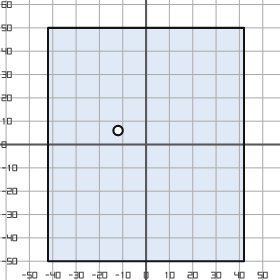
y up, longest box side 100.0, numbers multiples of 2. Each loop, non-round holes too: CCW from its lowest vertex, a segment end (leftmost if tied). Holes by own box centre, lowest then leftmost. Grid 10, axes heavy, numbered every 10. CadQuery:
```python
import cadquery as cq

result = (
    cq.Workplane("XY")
    .moveTo(-42.0, -50.0)
    .lineTo(42.0, -50.0)
    .lineTo(42.0, 50.0)
    .lineTo(-42.0, 50.0)
    .close()
    .moveTo(-12.0, 6.0)
    .circle(2.0)
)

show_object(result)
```